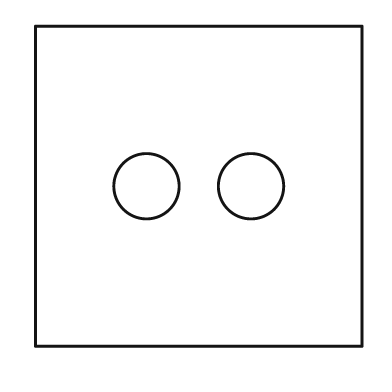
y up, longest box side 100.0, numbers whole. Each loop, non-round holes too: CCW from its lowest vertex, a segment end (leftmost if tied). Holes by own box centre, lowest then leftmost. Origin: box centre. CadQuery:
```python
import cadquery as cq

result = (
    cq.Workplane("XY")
    .moveTo(-50.0, -49.0)
    .lineTo(50.0, -49.0)
    .lineTo(50.0, 49.0)
    .lineTo(-50.0, 49.0)
    .close()
    .moveTo(-16.0, 0.0)
    .circle(10.0)
    .moveTo(16.0, 0.0)
    .circle(10.0)
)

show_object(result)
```